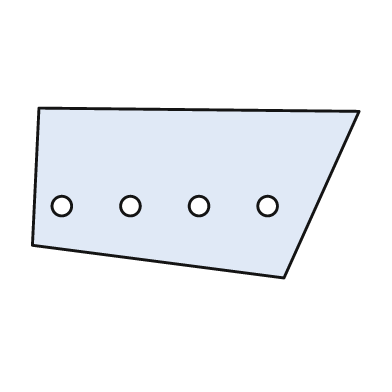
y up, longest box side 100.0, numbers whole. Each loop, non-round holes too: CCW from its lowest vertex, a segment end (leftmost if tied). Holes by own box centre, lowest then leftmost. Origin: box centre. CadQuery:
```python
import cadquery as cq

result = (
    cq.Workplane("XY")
    .moveTo(27.0, -26.0)
    .lineTo(50.0, 25.0)
    .lineTo(-48.0, 26.0)
    .lineTo(-50.0, -16.0)
    .close()
    .moveTo(-41.0, -4.0)
    .circle(3.0)
    .moveTo(-20.0, -4.0)
    .circle(3.0)
    .moveTo(1.0, -4.0)
    .circle(3.0)
    .moveTo(22.0, -4.0)
    .circle(3.0)
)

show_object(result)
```